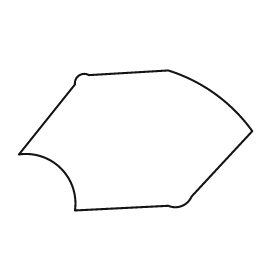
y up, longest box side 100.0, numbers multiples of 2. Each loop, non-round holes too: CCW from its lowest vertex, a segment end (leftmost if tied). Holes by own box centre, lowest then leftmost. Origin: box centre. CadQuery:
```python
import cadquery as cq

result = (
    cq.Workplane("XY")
    .moveTo(-26.0, -30.0)
    .lineTo(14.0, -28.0)
    .threePointArc((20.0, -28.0), (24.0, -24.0))
    .lineTo(50.0, 4.0)
    .threePointArc((34.0, 20.0), (14.0, 30.0))
    .lineTo(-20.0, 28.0)
    .threePointArc((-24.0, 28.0), (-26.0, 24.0))
    .lineTo(-50.0, -6.0)
    .threePointArc((-32.0, -12.0), (-26.0, -30.0))
    .close()
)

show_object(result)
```